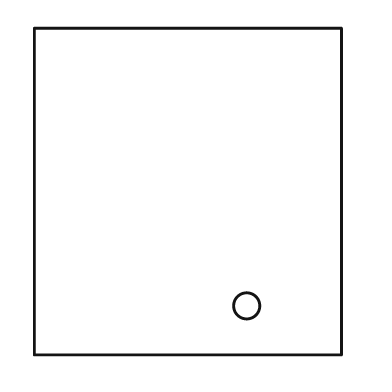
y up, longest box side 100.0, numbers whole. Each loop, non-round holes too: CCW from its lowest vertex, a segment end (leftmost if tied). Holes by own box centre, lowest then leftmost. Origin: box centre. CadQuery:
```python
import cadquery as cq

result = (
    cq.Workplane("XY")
    .moveTo(-47.0, -50.0)
    .lineTo(47.0, -50.0)
    .lineTo(47.0, 50.0)
    .lineTo(-47.0, 50.0)
    .close()
    .moveTo(18.0, -35.0)
    .circle(4.0)
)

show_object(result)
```